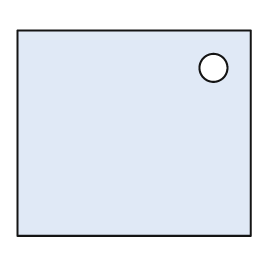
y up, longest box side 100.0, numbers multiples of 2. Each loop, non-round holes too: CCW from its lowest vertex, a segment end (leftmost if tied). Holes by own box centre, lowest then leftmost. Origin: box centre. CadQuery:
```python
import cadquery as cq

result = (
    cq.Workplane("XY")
    .moveTo(-50.0, -44.0)
    .lineTo(50.0, -44.0)
    .lineTo(50.0, 44.0)
    .lineTo(-50.0, 44.0)
    .close()
    .moveTo(34.0, 28.0)
    .circle(6.0)
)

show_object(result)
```